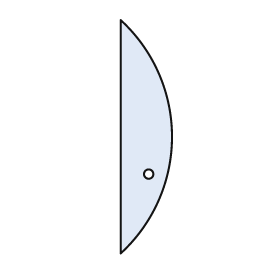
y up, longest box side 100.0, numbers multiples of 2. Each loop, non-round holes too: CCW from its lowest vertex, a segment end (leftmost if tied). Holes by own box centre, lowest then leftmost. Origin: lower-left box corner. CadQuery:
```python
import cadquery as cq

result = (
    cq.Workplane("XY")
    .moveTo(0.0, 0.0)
    .threePointArc((22.0, 50.0), (0.0, 100.0))
    .close()
    .moveTo(12.0, 34.0)
    .circle(2.0)
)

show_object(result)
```